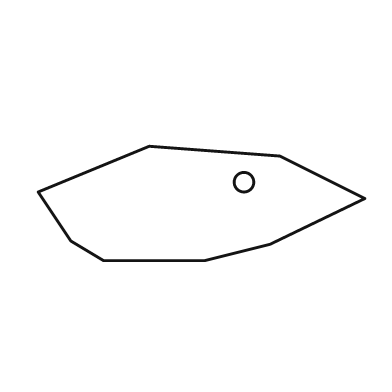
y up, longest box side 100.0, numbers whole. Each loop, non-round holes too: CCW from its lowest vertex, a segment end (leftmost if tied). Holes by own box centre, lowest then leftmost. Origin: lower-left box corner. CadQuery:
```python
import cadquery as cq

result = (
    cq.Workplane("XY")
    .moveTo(20.0, 0.0)
    .lineTo(51.0, 0.0)
    .lineTo(71.0, 5.0)
    .lineTo(100.0, 19.0)
    .lineTo(74.0, 32.0)
    .lineTo(34.0, 35.0)
    .lineTo(0.0, 21.0)
    .lineTo(10.0, 6.0)
    .close()
    .moveTo(63.0, 24.0)
    .circle(3.0)
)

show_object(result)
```